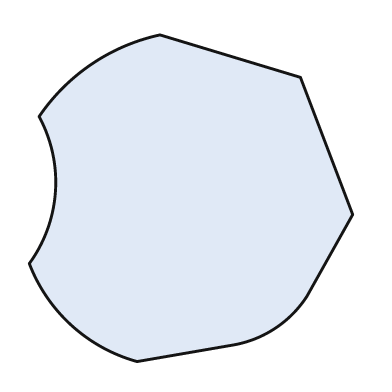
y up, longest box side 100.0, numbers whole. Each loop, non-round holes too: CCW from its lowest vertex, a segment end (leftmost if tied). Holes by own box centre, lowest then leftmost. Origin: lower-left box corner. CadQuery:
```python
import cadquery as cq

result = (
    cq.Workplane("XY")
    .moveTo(33.0, 0.0)
    .lineTo(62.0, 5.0)
    .threePointArc((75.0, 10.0), (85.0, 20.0))
    .lineTo(99.0, 45.0)
    .lineTo(83.0, 87.0)
    .lineTo(40.0, 100.0)
    .threePointArc((19.0, 91.0), (3.0, 75.0))
    .threePointArc((8.0, 52.0), (0.0, 30.0))
    .threePointArc((13.0, 11.0), (33.0, 0.0))
    .close()
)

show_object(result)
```